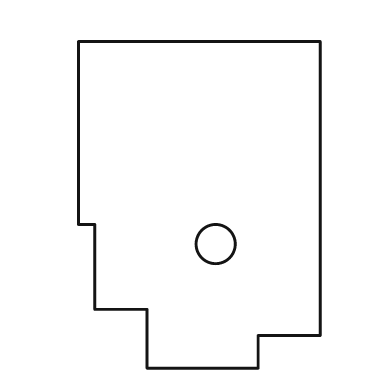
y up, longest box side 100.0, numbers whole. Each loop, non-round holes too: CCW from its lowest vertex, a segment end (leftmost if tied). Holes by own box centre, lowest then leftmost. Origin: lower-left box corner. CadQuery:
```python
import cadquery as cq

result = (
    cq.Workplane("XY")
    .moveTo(21.0, 0.0)
    .lineTo(55.0, 0.0)
    .lineTo(55.0, 10.0)
    .lineTo(74.0, 10.0)
    .lineTo(74.0, 100.0)
    .lineTo(0.0, 100.0)
    .lineTo(0.0, 44.0)
    .lineTo(5.0, 44.0)
    .lineTo(5.0, 18.0)
    .lineTo(21.0, 18.0)
    .close()
    .moveTo(42.0, 38.0)
    .circle(6.0)
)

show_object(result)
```